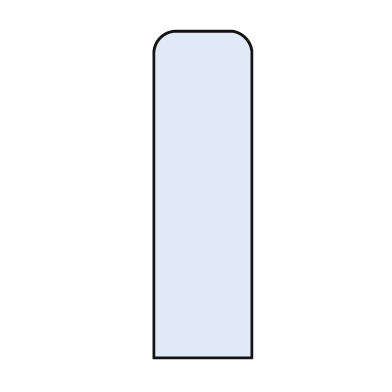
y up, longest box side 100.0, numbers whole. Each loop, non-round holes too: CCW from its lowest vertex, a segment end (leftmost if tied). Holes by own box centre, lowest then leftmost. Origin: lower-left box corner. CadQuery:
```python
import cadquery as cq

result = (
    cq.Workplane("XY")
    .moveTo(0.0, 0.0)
    .lineTo(30.0, 0.0)
    .lineTo(30.0, 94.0)
    .threePointArc((28.0, 98.0), (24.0, 100.0))
    .lineTo(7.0, 100.0)
    .threePointArc((2.0, 98.0), (0.0, 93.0))
    .close()
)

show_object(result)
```